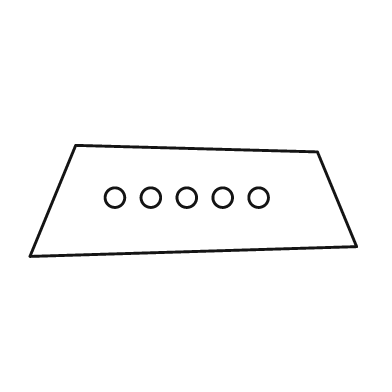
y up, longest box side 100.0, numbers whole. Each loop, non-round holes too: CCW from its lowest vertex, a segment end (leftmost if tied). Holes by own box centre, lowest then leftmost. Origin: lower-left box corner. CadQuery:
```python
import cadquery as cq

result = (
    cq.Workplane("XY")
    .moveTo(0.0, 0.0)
    .lineTo(100.0, 3.0)
    .lineTo(88.0, 32.0)
    .lineTo(14.0, 34.0)
    .close()
    .moveTo(26.0, 18.0)
    .circle(3.0)
    .moveTo(37.0, 18.0)
    .circle(3.0)
    .moveTo(48.0, 18.0)
    .circle(3.0)
    .moveTo(59.0, 18.0)
    .circle(3.0)
    .moveTo(70.0, 18.0)
    .circle(3.0)
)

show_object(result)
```